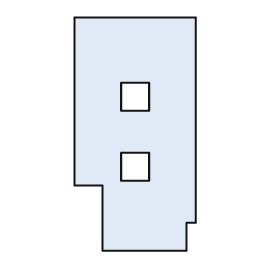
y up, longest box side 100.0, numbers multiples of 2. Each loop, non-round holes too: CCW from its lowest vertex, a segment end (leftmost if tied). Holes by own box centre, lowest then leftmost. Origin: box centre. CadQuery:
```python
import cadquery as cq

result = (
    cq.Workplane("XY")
    .moveTo(-14.0, -50.0)
    .lineTo(22.0, -50.0)
    .lineTo(22.0, -38.0)
    .lineTo(26.0, -38.0)
    .lineTo(26.0, 50.0)
    .lineTo(-26.0, 50.0)
    .lineTo(-26.0, -22.0)
    .lineTo(-14.0, -22.0)
    .close()
    .moveTo(-6.0, -20.0)
    .lineTo(6.0, -20.0)
    .lineTo(6.0, -8.0)
    .lineTo(-6.0, -8.0)
    .close()
    .moveTo(-6.0, 10.0)
    .lineTo(6.0, 10.0)
    .lineTo(6.0, 22.0)
    .lineTo(-6.0, 22.0)
    .close()
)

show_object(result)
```